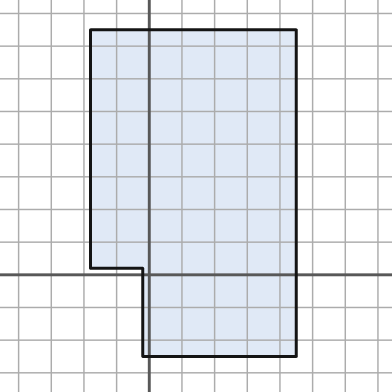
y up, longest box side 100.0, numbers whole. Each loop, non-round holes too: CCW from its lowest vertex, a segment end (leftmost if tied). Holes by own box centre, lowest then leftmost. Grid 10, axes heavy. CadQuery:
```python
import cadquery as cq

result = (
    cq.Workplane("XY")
    .moveTo(-2.0, -25.0)
    .lineTo(45.0, -25.0)
    .lineTo(45.0, 75.0)
    .lineTo(-18.0, 75.0)
    .lineTo(-18.0, 2.0)
    .lineTo(-2.0, 2.0)
    .close()
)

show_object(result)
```